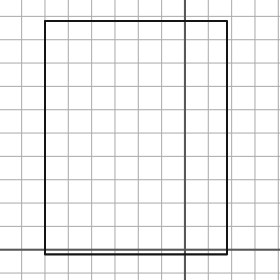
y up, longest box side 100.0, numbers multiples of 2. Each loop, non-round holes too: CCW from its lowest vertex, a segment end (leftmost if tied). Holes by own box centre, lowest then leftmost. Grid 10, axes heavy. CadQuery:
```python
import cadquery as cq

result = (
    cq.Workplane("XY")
    .moveTo(-60.0, -2.0)
    .lineTo(18.0, -2.0)
    .lineTo(18.0, 98.0)
    .lineTo(-60.0, 98.0)
    .close()
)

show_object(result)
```